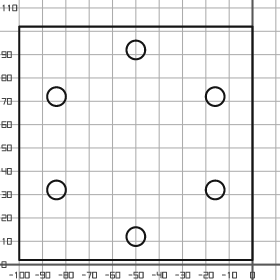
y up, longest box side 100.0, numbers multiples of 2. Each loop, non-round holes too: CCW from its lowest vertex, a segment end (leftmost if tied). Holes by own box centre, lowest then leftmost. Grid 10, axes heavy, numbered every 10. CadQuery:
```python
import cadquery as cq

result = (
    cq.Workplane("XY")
    .moveTo(-100.0, 2.0)
    .lineTo(0.0, 2.0)
    .lineTo(0.0, 102.0)
    .lineTo(-100.0, 102.0)
    .close()
    .moveTo(-50.0, 12.0)
    .circle(4.0)
    .moveTo(-84.0, 32.0)
    .circle(4.0)
    .moveTo(-16.0, 32.0)
    .circle(4.0)
    .moveTo(-84.0, 72.0)
    .circle(4.0)
    .moveTo(-16.0, 72.0)
    .circle(4.0)
    .moveTo(-50.0, 92.0)
    .circle(4.0)
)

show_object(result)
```